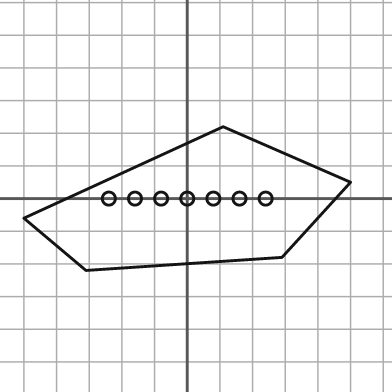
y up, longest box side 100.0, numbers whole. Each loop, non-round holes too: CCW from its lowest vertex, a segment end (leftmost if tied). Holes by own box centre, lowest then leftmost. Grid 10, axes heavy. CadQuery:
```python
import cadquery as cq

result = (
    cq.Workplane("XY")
    .moveTo(-31.0, -22.0)
    .lineTo(29.0, -18.0)
    .lineTo(50.0, 5.0)
    .lineTo(11.0, 22.0)
    .lineTo(-50.0, -6.0)
    .close()
    .moveTo(-24.0, 0.0)
    .circle(2.0)
    .moveTo(-16.0, 0.0)
    .circle(2.0)
    .moveTo(-8.0, 0.0)
    .circle(2.0)
    .moveTo(0.0, 0.0)
    .circle(2.0)
    .moveTo(8.0, 0.0)
    .circle(2.0)
    .moveTo(16.0, 0.0)
    .circle(2.0)
    .moveTo(24.0, 0.0)
    .circle(2.0)
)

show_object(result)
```